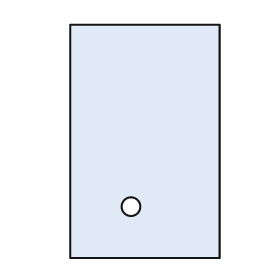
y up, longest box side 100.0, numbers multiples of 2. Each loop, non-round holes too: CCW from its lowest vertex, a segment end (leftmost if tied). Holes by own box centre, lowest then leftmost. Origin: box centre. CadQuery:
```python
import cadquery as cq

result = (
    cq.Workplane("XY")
    .moveTo(-32.0, -50.0)
    .lineTo(32.0, -50.0)
    .lineTo(32.0, 50.0)
    .lineTo(-32.0, 50.0)
    .close()
    .moveTo(-6.0, -28.0)
    .circle(4.0)
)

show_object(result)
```